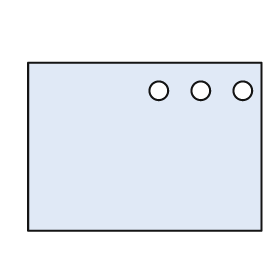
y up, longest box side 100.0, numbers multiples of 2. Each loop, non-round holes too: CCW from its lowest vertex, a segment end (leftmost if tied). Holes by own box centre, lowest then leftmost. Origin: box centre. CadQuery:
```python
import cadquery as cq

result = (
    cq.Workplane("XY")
    .moveTo(-50.0, -36.0)
    .lineTo(50.0, -36.0)
    .lineTo(50.0, 36.0)
    .lineTo(-50.0, 36.0)
    .close()
    .moveTo(6.0, 24.0)
    .circle(4.0)
    .moveTo(24.0, 24.0)
    .circle(4.0)
    .moveTo(42.0, 24.0)
    .circle(4.0)
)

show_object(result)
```